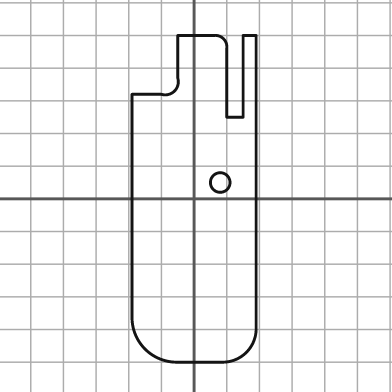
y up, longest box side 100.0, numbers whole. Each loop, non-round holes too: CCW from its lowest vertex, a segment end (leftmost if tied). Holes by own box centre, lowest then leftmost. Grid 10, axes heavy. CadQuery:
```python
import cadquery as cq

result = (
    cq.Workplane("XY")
    .moveTo(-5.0, -50.0)
    .lineTo(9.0, -50.0)
    .threePointArc((16.0, -47.0), (19.0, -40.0))
    .lineTo(19.0, 50.0)
    .lineTo(15.0, 50.0)
    .lineTo(15.0, 25.0)
    .lineTo(10.0, 25.0)
    .lineTo(10.0, 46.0)
    .threePointArc((9.0, 49.0), (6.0, 50.0))
    .lineTo(-5.0, 50.0)
    .lineTo(-5.0, 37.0)
    .threePointArc((-6.0, 33.0), (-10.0, 32.0))
    .lineTo(-19.0, 32.0)
    .lineTo(-19.0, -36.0)
    .threePointArc((-15.0, -46.0), (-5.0, -50.0))
    .close()
    .moveTo(8.0, 5.0)
    .circle(3.0)
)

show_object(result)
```